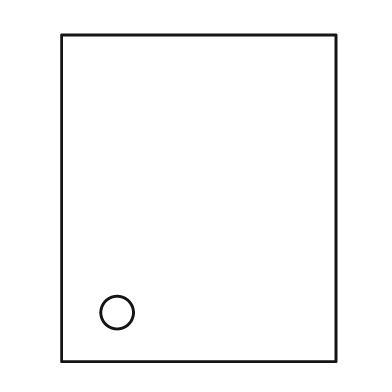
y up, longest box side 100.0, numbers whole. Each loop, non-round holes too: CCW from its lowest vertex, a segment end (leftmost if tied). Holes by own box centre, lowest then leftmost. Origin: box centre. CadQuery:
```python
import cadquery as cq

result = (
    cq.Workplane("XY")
    .moveTo(-42.0, -50.0)
    .lineTo(42.0, -50.0)
    .lineTo(42.0, 50.0)
    .lineTo(-42.0, 50.0)
    .close()
    .moveTo(-25.0, -35.0)
    .circle(5.0)
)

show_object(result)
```